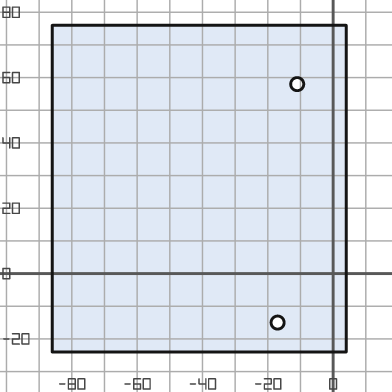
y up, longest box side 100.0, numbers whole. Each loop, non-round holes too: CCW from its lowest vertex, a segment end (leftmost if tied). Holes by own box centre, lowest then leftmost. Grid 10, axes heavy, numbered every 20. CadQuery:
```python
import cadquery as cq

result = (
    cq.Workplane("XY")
    .moveTo(-86.0, -24.0)
    .lineTo(4.0, -24.0)
    .lineTo(4.0, 76.0)
    .lineTo(-86.0, 76.0)
    .close()
    .moveTo(-17.0, -15.0)
    .circle(2.0)
    .moveTo(-11.0, 58.0)
    .circle(2.0)
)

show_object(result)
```